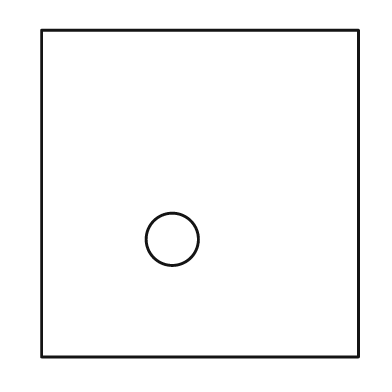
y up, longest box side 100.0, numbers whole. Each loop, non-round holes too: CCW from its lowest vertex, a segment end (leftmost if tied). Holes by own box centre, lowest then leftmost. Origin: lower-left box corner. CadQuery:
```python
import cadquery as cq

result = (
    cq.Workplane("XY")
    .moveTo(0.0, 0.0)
    .lineTo(97.0, 0.0)
    .lineTo(97.0, 100.0)
    .lineTo(0.0, 100.0)
    .close()
    .moveTo(40.0, 36.0)
    .circle(8.0)
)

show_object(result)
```